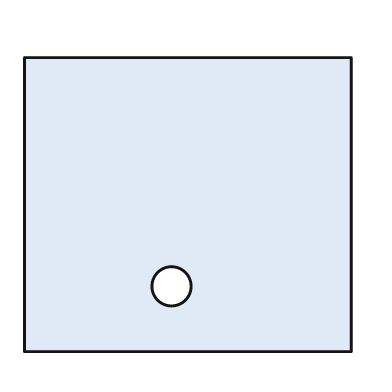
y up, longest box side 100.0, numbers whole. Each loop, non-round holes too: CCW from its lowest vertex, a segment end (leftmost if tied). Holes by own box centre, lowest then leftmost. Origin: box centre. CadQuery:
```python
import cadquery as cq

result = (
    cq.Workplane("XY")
    .moveTo(-50.0, -45.0)
    .lineTo(50.0, -45.0)
    .lineTo(50.0, 45.0)
    .lineTo(-50.0, 45.0)
    .close()
    .moveTo(-5.0, -25.0)
    .circle(6.0)
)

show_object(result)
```